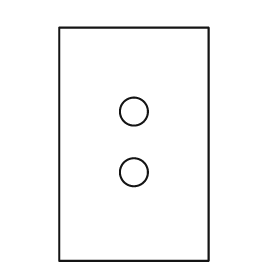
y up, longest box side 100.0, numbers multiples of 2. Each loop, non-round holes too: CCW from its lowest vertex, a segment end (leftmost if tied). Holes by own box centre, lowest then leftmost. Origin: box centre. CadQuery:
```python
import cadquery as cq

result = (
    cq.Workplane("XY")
    .moveTo(-32.0, -50.0)
    .lineTo(32.0, -50.0)
    .lineTo(32.0, 50.0)
    .lineTo(-32.0, 50.0)
    .close()
    .moveTo(0.0, -12.0)
    .circle(6.0)
    .moveTo(0.0, 14.0)
    .circle(6.0)
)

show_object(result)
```